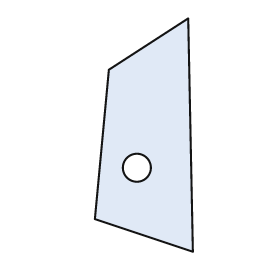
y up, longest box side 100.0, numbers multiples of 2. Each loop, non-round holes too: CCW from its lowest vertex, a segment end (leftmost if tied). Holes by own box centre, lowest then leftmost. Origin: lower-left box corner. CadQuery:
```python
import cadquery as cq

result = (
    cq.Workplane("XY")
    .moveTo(42.0, 0.0)
    .lineTo(40.0, 100.0)
    .lineTo(6.0, 78.0)
    .lineTo(0.0, 14.0)
    .close()
    .moveTo(18.0, 36.0)
    .circle(6.0)
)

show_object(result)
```